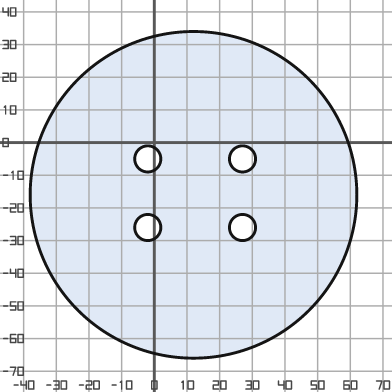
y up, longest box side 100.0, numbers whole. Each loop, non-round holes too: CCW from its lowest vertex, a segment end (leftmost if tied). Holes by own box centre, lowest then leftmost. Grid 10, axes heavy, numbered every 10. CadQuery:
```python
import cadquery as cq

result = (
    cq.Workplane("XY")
    .moveTo(12.0, -16.0)
    .circle(50.0)
    .moveTo(-2.0, -26.0)
    .circle(4.0)
    .moveTo(27.0, -26.0)
    .circle(4.0)
    .moveTo(-2.0, -5.0)
    .circle(4.0)
    .moveTo(27.0, -5.0)
    .circle(4.0)
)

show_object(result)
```